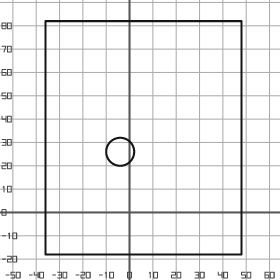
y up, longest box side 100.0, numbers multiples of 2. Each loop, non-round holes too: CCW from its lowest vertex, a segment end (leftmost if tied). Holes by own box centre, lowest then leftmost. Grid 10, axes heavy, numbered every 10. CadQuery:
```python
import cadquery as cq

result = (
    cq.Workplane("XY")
    .moveTo(-36.0, -18.0)
    .lineTo(48.0, -18.0)
    .lineTo(48.0, 82.0)
    .lineTo(-36.0, 82.0)
    .close()
    .moveTo(-4.0, 26.0)
    .circle(6.0)
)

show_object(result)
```